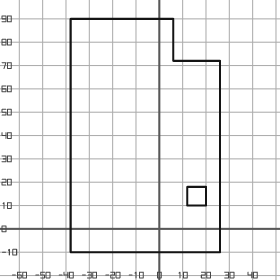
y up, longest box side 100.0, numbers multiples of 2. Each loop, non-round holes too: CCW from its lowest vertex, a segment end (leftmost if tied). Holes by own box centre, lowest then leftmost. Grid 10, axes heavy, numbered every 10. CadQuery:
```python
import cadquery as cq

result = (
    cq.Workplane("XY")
    .moveTo(-38.0, -10.0)
    .lineTo(26.0, -10.0)
    .lineTo(26.0, 72.0)
    .lineTo(6.0, 72.0)
    .lineTo(6.0, 90.0)
    .lineTo(-38.0, 90.0)
    .close()
    .moveTo(12.0, 10.0)
    .lineTo(20.0, 10.0)
    .lineTo(20.0, 18.0)
    .lineTo(12.0, 18.0)
    .close()
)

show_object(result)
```